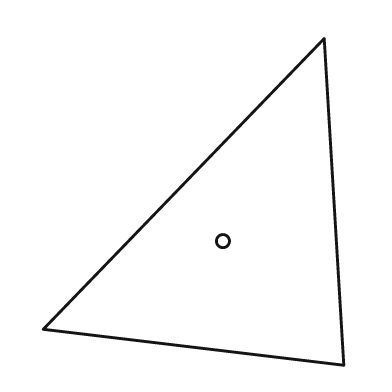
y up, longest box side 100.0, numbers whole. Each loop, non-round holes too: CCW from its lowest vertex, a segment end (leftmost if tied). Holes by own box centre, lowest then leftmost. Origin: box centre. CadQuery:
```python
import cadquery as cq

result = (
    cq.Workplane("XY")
    .moveTo(46.0, -50.0)
    .lineTo(40.0, 50.0)
    .lineTo(-46.0, -39.0)
    .close()
    .moveTo(9.0, -12.0)
    .circle(2.0)
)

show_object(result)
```